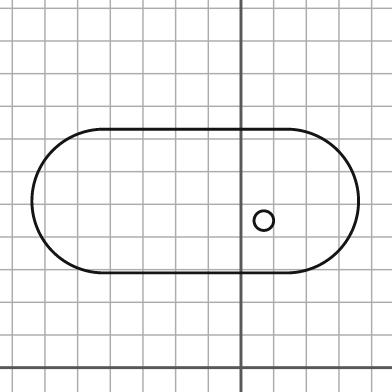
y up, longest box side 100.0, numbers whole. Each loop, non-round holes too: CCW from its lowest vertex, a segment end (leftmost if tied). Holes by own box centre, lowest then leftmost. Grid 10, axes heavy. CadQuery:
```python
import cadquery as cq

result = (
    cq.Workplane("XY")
    .moveTo(-42.0, 29.0)
    .lineTo(14.0, 29.0)
    .threePointArc((36.0, 51.0), (14.0, 73.0))
    .lineTo(-42.0, 73.0)
    .threePointArc((-64.0, 51.0), (-42.0, 29.0))
    .close()
    .moveTo(7.0, 45.0)
    .circle(3.0)
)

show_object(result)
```